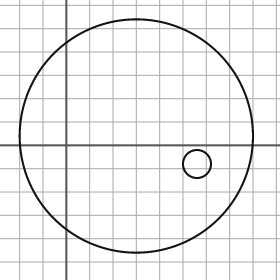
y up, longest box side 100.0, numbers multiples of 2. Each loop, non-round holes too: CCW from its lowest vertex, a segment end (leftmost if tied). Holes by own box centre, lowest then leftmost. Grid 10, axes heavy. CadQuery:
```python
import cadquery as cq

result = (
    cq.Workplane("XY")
    .moveTo(30.0, 4.0)
    .circle(50.0)
    .moveTo(56.0, -8.0)
    .circle(6.0)
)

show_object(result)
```